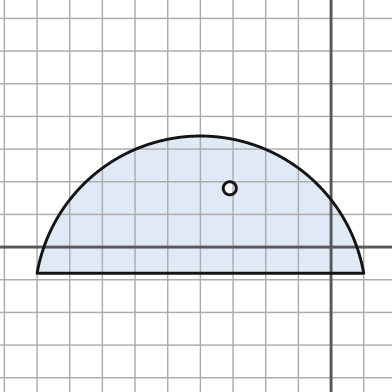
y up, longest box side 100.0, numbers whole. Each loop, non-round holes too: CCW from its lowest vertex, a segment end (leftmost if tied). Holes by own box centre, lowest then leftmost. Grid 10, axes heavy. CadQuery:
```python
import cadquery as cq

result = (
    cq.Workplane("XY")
    .moveTo(-90.0, -8.0)
    .lineTo(10.0, -8.0)
    .threePointArc((-40.0, 34.0), (-90.0, -8.0))
    .close()
    .moveTo(-31.0, 18.0)
    .circle(2.0)
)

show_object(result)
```